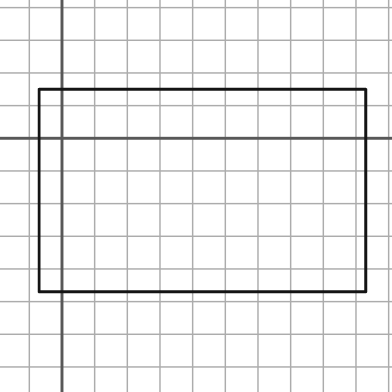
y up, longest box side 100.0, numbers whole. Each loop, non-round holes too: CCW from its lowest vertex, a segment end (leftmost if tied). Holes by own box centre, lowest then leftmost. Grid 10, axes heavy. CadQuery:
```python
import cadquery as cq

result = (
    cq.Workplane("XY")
    .moveTo(-7.0, -47.0)
    .lineTo(93.0, -47.0)
    .lineTo(93.0, 15.0)
    .lineTo(-7.0, 15.0)
    .close()
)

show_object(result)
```